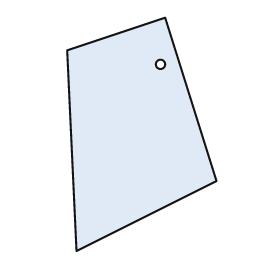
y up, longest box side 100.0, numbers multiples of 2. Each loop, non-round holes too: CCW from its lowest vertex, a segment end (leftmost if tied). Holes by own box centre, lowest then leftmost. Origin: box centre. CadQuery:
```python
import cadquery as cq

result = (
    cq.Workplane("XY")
    .moveTo(-28.0, -50.0)
    .lineTo(32.0, -20.0)
    .lineTo(10.0, 50.0)
    .lineTo(-32.0, 36.0)
    .close()
    .moveTo(8.0, 30.0)
    .circle(2.0)
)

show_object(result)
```